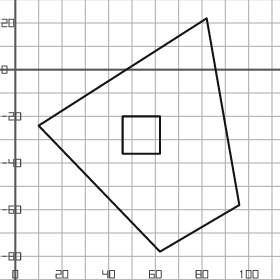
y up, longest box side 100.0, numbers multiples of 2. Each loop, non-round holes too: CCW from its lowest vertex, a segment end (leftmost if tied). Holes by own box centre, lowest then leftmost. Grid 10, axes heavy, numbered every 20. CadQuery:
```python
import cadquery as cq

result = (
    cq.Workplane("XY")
    .moveTo(62.0, -78.0)
    .lineTo(96.0, -58.0)
    .lineTo(82.0, 22.0)
    .lineTo(10.0, -24.0)
    .close()
    .moveTo(46.0, -36.0)
    .lineTo(62.0, -36.0)
    .lineTo(62.0, -20.0)
    .lineTo(46.0, -20.0)
    .close()
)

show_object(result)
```